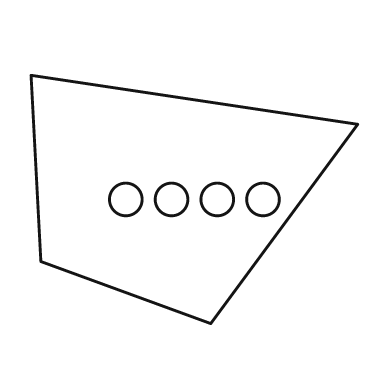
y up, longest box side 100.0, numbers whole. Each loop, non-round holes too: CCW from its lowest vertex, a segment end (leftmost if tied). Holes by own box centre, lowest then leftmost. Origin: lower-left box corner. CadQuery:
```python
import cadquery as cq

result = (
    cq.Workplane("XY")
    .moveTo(55.0, 0.0)
    .lineTo(100.0, 61.0)
    .lineTo(0.0, 76.0)
    .lineTo(3.0, 19.0)
    .close()
    .moveTo(29.0, 38.0)
    .circle(5.0)
    .moveTo(43.0, 38.0)
    .circle(5.0)
    .moveTo(57.0, 38.0)
    .circle(5.0)
    .moveTo(71.0, 38.0)
    .circle(5.0)
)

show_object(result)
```